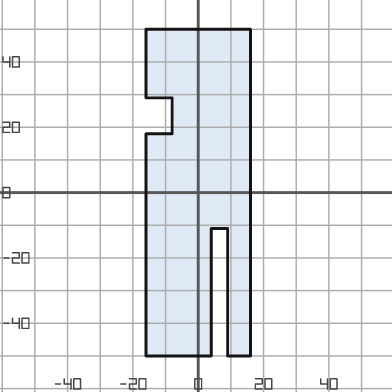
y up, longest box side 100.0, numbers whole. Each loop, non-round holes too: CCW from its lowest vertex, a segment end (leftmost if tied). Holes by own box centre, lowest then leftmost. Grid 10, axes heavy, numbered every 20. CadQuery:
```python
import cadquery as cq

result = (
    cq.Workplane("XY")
    .moveTo(-16.0, -50.0)
    .lineTo(4.0, -50.0)
    .lineTo(4.0, -11.0)
    .lineTo(9.0, -11.0)
    .lineTo(9.0, -50.0)
    .lineTo(16.0, -50.0)
    .lineTo(16.0, 50.0)
    .lineTo(-16.0, 50.0)
    .lineTo(-16.0, 29.0)
    .lineTo(-8.0, 29.0)
    .lineTo(-8.0, 18.0)
    .lineTo(-16.0, 18.0)
    .close()
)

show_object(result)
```